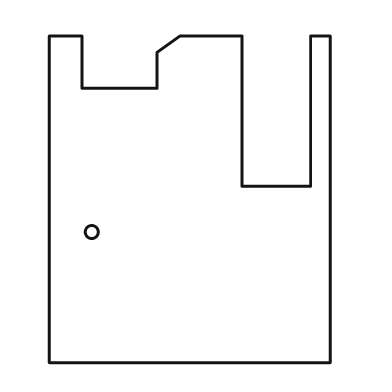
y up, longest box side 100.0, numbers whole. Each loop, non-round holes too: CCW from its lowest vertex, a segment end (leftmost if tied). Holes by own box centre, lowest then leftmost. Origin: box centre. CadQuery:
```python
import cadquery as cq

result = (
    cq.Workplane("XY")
    .moveTo(-43.0, -50.0)
    .lineTo(43.0, -50.0)
    .lineTo(43.0, 50.0)
    .lineTo(37.0, 50.0)
    .lineTo(37.0, 4.0)
    .lineTo(16.0, 4.0)
    .lineTo(16.0, 50.0)
    .lineTo(-3.0, 50.0)
    .lineTo(-10.0, 45.0)
    .lineTo(-10.0, 34.0)
    .lineTo(-33.0, 34.0)
    .lineTo(-33.0, 50.0)
    .lineTo(-43.0, 50.0)
    .close()
    .moveTo(-30.0, -10.0)
    .circle(2.0)
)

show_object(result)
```